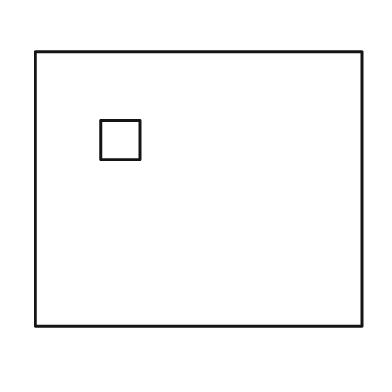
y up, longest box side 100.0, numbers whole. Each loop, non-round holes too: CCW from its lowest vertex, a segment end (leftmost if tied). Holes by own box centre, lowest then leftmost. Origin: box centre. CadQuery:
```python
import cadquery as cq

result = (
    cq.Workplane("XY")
    .moveTo(-50.0, -42.0)
    .lineTo(50.0, -42.0)
    .lineTo(50.0, 42.0)
    .lineTo(-50.0, 42.0)
    .close()
    .moveTo(-30.0, 9.0)
    .lineTo(-18.0, 9.0)
    .lineTo(-18.0, 21.0)
    .lineTo(-30.0, 21.0)
    .close()
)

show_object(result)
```